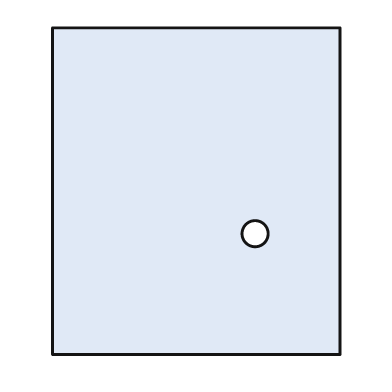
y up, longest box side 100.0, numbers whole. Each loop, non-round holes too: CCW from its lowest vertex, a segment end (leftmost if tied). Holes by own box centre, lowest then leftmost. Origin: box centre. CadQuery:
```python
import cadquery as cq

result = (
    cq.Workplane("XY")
    .moveTo(-44.0, -50.0)
    .lineTo(44.0, -50.0)
    .lineTo(44.0, 50.0)
    .lineTo(-44.0, 50.0)
    .close()
    .moveTo(18.0, -13.0)
    .circle(4.0)
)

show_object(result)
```